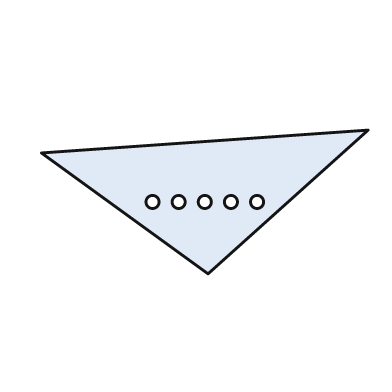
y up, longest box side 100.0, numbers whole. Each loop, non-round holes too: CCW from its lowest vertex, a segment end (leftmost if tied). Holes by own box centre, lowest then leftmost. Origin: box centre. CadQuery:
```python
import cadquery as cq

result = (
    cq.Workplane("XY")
    .moveTo(1.0, -22.0)
    .lineTo(50.0, 22.0)
    .lineTo(-50.0, 15.0)
    .close()
    .moveTo(-16.0, 0.0)
    .circle(2.0)
    .moveTo(-8.0, 0.0)
    .circle(2.0)
    .moveTo(0.0, 0.0)
    .circle(2.0)
    .moveTo(8.0, 0.0)
    .circle(2.0)
    .moveTo(16.0, 0.0)
    .circle(2.0)
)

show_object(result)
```